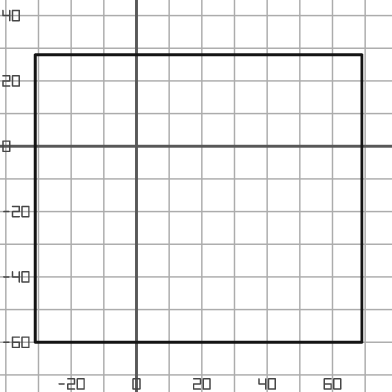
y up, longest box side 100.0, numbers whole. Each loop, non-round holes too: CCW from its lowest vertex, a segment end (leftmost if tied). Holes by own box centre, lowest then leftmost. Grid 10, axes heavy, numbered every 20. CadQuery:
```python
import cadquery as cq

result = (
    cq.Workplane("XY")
    .moveTo(-31.0, -60.0)
    .lineTo(69.0, -60.0)
    .lineTo(69.0, 28.0)
    .lineTo(-31.0, 28.0)
    .close()
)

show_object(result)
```